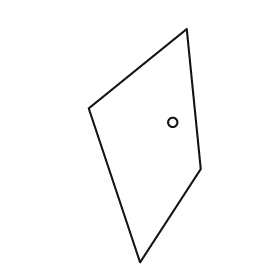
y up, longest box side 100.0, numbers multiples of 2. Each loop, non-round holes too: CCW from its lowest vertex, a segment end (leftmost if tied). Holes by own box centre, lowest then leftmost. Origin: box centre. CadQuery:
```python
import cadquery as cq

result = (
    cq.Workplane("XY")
    .moveTo(-2.0, -50.0)
    .lineTo(24.0, -10.0)
    .lineTo(18.0, 50.0)
    .lineTo(-24.0, 16.0)
    .close()
    .moveTo(12.0, 10.0)
    .circle(2.0)
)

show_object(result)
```